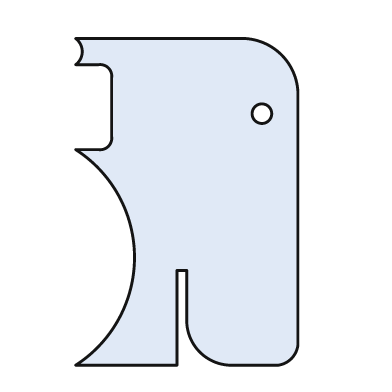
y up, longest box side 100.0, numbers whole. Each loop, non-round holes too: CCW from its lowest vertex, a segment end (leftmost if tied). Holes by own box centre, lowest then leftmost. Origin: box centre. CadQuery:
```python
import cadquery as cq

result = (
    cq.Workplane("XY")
    .moveTo(-34.0, -50.0)
    .lineTo(-3.0, -50.0)
    .lineTo(-3.0, -21.0)
    .lineTo(0.0, -21.0)
    .lineTo(0.0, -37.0)
    .threePointArc((4.0, -46.0), (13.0, -50.0))
    .lineTo(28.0, -50.0)
    .threePointArc((32.0, -48.0), (34.0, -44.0))
    .lineTo(34.0, 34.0)
    .threePointArc((29.0, 45.0), (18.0, 50.0))
    .lineTo(-34.0, 50.0)
    .threePointArc((-32.0, 46.0), (-34.0, 42.0))
    .lineTo(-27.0, 42.0)
    .threePointArc((-24.0, 41.0), (-23.0, 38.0))
    .lineTo(-23.0, 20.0)
    .threePointArc((-24.0, 17.0), (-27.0, 16.0))
    .lineTo(-34.0, 16.0)
    .threePointArc((-16.0, -17.0), (-34.0, -50.0))
    .close()
    .moveTo(23.0, 27.0)
    .circle(3.0)
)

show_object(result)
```